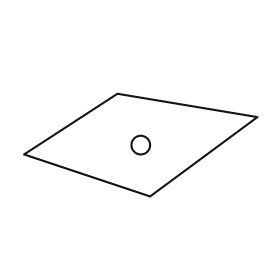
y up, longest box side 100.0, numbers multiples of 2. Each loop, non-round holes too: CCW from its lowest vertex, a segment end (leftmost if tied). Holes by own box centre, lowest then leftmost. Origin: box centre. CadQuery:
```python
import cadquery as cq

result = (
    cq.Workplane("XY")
    .moveTo(4.0, -22.0)
    .lineTo(50.0, 12.0)
    .lineTo(-10.0, 22.0)
    .lineTo(-50.0, -4.0)
    .close()
    .moveTo(0.0, 0.0)
    .circle(4.0)
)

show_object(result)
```